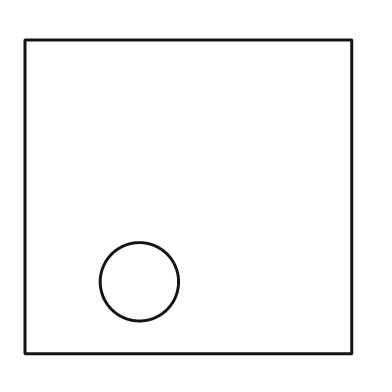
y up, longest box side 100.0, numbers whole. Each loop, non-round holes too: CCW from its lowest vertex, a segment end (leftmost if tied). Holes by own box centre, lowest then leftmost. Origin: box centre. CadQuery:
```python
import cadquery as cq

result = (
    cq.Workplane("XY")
    .moveTo(-50.0, -48.0)
    .lineTo(50.0, -48.0)
    .lineTo(50.0, 48.0)
    .lineTo(-50.0, 48.0)
    .close()
    .moveTo(-15.0, -26.0)
    .circle(12.0)
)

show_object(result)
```